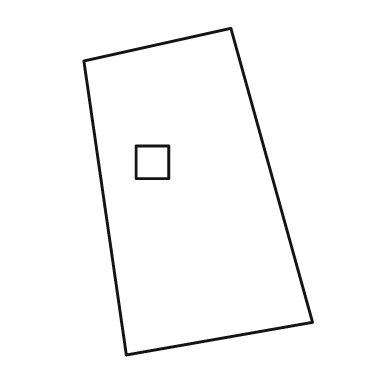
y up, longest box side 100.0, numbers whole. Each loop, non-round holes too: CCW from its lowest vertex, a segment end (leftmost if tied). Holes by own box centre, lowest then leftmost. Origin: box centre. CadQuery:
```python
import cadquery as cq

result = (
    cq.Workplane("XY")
    .moveTo(-22.0, -50.0)
    .lineTo(35.0, -40.0)
    .lineTo(10.0, 50.0)
    .lineTo(-35.0, 40.0)
    .close()
    .moveTo(-19.0, 4.0)
    .lineTo(-9.0, 4.0)
    .lineTo(-9.0, 14.0)
    .lineTo(-19.0, 14.0)
    .close()
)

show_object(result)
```